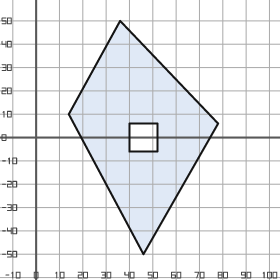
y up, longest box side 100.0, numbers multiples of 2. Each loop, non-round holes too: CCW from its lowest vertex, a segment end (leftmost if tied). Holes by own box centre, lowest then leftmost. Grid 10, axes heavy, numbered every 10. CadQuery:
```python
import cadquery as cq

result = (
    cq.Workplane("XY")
    .moveTo(46.0, -50.0)
    .lineTo(78.0, 6.0)
    .lineTo(36.0, 50.0)
    .lineTo(14.0, 10.0)
    .close()
    .moveTo(40.0, -6.0)
    .lineTo(52.0, -6.0)
    .lineTo(52.0, 6.0)
    .lineTo(40.0, 6.0)
    .close()
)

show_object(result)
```